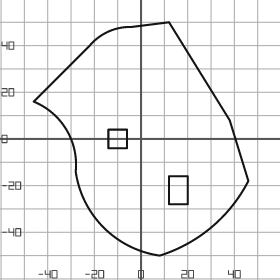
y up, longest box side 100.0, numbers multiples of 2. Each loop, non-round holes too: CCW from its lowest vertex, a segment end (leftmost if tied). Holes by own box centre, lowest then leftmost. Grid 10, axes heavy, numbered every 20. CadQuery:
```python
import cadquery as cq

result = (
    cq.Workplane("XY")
    .moveTo(8.0, -50.0)
    .threePointArc((30.0, -38.0), (46.0, -18.0))
    .lineTo(38.0, 8.0)
    .lineTo(12.0, 50.0)
    .lineTo(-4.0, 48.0)
    .threePointArc((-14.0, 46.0), (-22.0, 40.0))
    .lineTo(-46.0, 16.0)
    .threePointArc((-32.0, 4.0), (-28.0, -14.0))
    .threePointArc((-16.0, -38.0), (8.0, -50.0))
    .close()
    .moveTo(12.0, -28.0)
    .lineTo(20.0, -28.0)
    .lineTo(20.0, -16.0)
    .lineTo(12.0, -16.0)
    .close()
    .moveTo(-14.0, -4.0)
    .lineTo(-6.0, -4.0)
    .lineTo(-6.0, 4.0)
    .lineTo(-14.0, 4.0)
    .close()
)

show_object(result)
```